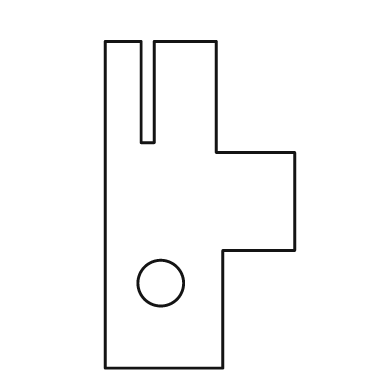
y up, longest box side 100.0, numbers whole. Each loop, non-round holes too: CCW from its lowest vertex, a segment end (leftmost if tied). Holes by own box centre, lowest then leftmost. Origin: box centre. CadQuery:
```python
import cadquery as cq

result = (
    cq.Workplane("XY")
    .moveTo(-29.0, -50.0)
    .lineTo(7.0, -50.0)
    .lineTo(7.0, -14.0)
    .lineTo(29.0, -14.0)
    .lineTo(29.0, 16.0)
    .lineTo(5.0, 16.0)
    .lineTo(5.0, 50.0)
    .lineTo(-14.0, 50.0)
    .lineTo(-14.0, 19.0)
    .lineTo(-18.0, 19.0)
    .lineTo(-18.0, 50.0)
    .lineTo(-29.0, 50.0)
    .close()
    .moveTo(-12.0, -24.0)
    .circle(7.0)
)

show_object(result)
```